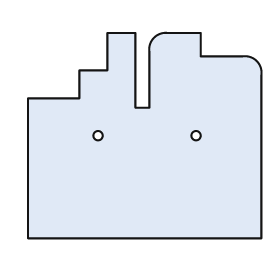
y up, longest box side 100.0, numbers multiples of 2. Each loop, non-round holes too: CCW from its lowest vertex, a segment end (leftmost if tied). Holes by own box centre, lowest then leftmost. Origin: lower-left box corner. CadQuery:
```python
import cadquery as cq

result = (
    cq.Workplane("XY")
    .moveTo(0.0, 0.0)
    .lineTo(100.0, 0.0)
    .lineTo(100.0, 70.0)
    .threePointArc((98.0, 76.0), (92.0, 78.0))
    .lineTo(74.0, 78.0)
    .lineTo(74.0, 88.0)
    .lineTo(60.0, 88.0)
    .threePointArc((54.0, 86.0), (52.0, 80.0))
    .lineTo(52.0, 56.0)
    .lineTo(46.0, 56.0)
    .lineTo(46.0, 88.0)
    .lineTo(34.0, 88.0)
    .lineTo(34.0, 72.0)
    .lineTo(22.0, 72.0)
    .lineTo(22.0, 60.0)
    .lineTo(0.0, 60.0)
    .close()
    .moveTo(30.0, 44.0)
    .circle(2.0)
    .moveTo(72.0, 44.0)
    .circle(2.0)
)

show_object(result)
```